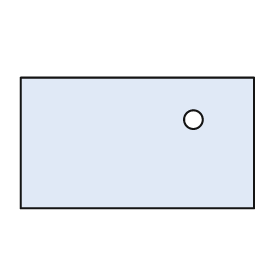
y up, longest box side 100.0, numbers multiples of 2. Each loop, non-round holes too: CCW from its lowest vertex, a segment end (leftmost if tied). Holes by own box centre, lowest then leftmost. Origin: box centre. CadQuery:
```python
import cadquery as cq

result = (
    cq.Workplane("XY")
    .moveTo(-50.0, -28.0)
    .lineTo(50.0, -28.0)
    .lineTo(50.0, 28.0)
    .lineTo(-50.0, 28.0)
    .close()
    .moveTo(24.0, 10.0)
    .circle(4.0)
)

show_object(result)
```